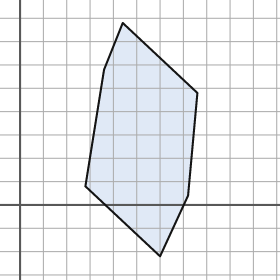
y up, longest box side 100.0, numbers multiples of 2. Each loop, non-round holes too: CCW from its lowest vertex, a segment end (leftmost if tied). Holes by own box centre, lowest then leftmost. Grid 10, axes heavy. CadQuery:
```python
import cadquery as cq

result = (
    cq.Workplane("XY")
    .moveTo(60.0, -22.0)
    .lineTo(72.0, 4.0)
    .lineTo(76.0, 48.0)
    .lineTo(44.0, 78.0)
    .lineTo(36.0, 58.0)
    .lineTo(28.0, 8.0)
    .close()
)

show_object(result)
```